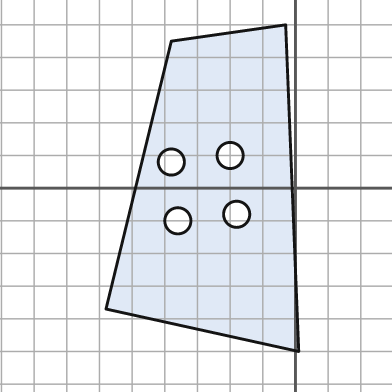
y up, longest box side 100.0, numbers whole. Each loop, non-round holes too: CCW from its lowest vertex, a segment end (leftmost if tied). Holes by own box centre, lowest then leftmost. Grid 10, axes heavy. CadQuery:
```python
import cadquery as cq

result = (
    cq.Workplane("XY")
    .moveTo(1.0, -50.0)
    .lineTo(-3.0, 50.0)
    .lineTo(-38.0, 45.0)
    .lineTo(-58.0, -37.0)
    .close()
    .moveTo(-36.0, -10.0)
    .circle(4.0)
    .moveTo(-18.0, -8.0)
    .circle(4.0)
    .moveTo(-38.0, 8.0)
    .circle(4.0)
    .moveTo(-20.0, 10.0)
    .circle(4.0)
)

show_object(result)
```